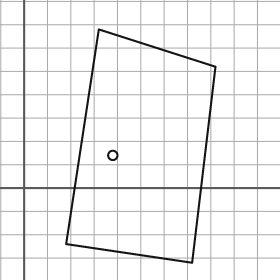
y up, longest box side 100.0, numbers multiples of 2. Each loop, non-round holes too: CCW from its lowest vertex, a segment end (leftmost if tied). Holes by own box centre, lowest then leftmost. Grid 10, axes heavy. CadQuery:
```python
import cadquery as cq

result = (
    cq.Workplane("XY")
    .moveTo(72.0, -32.0)
    .lineTo(82.0, 52.0)
    .lineTo(32.0, 68.0)
    .lineTo(18.0, -24.0)
    .close()
    .moveTo(38.0, 14.0)
    .circle(2.0)
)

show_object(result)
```